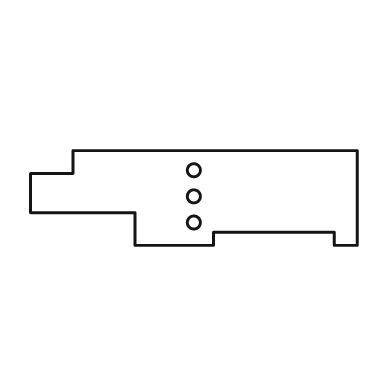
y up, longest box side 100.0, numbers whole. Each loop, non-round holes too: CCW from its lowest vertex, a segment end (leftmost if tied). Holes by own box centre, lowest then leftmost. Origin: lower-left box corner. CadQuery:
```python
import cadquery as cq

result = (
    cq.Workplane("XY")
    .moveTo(32.0, 0.0)
    .lineTo(56.0, 0.0)
    .lineTo(56.0, 4.0)
    .lineTo(93.0, 4.0)
    .lineTo(93.0, 0.0)
    .lineTo(100.0, 0.0)
    .lineTo(100.0, 29.0)
    .lineTo(13.0, 29.0)
    .lineTo(13.0, 22.0)
    .lineTo(0.0, 22.0)
    .lineTo(0.0, 10.0)
    .lineTo(32.0, 10.0)
    .close()
    .moveTo(50.0, 7.0)
    .circle(2.0)
    .moveTo(50.0, 15.0)
    .circle(2.0)
    .moveTo(50.0, 23.0)
    .circle(2.0)
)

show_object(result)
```